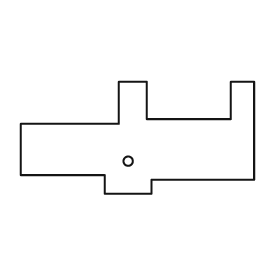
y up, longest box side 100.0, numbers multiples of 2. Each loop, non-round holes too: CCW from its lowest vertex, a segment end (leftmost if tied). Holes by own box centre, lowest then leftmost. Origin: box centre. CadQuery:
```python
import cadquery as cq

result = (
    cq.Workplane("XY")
    .moveTo(-14.0, -24.0)
    .lineTo(6.0, -24.0)
    .lineTo(6.0, -18.0)
    .lineTo(50.0, -18.0)
    .lineTo(50.0, 24.0)
    .lineTo(40.0, 24.0)
    .lineTo(40.0, 8.0)
    .lineTo(4.0, 8.0)
    .lineTo(4.0, 24.0)
    .lineTo(-8.0, 24.0)
    .lineTo(-8.0, 6.0)
    .lineTo(-50.0, 6.0)
    .lineTo(-50.0, -16.0)
    .lineTo(-14.0, -16.0)
    .close()
    .moveTo(-4.0, -10.0)
    .circle(2.0)
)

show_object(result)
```